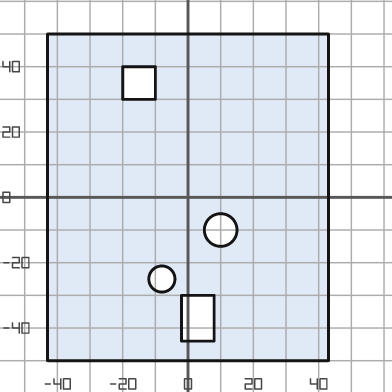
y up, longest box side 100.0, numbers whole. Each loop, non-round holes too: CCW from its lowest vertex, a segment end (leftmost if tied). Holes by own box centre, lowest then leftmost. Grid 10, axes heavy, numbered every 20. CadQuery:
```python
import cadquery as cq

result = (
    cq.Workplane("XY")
    .moveTo(-43.0, -50.0)
    .lineTo(43.0, -50.0)
    .lineTo(43.0, 50.0)
    .lineTo(-43.0, 50.0)
    .close()
    .moveTo(-2.0, -44.0)
    .lineTo(8.0, -44.0)
    .lineTo(8.0, -30.0)
    .lineTo(-2.0, -30.0)
    .close()
    .moveTo(-8.0, -25.0)
    .circle(4.0)
    .moveTo(10.0, -10.0)
    .circle(5.0)
    .moveTo(-20.0, 30.0)
    .lineTo(-10.0, 30.0)
    .lineTo(-10.0, 40.0)
    .lineTo(-20.0, 40.0)
    .close()
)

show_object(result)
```